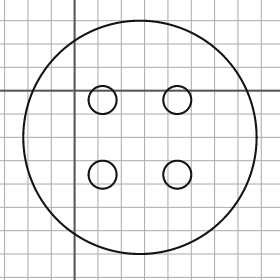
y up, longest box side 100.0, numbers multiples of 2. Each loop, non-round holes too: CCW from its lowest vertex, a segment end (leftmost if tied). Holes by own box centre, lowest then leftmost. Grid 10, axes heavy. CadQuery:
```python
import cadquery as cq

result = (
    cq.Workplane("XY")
    .moveTo(28.0, -20.0)
    .circle(50.0)
    .moveTo(12.0, -36.0)
    .circle(6.0)
    .moveTo(44.0, -36.0)
    .circle(6.0)
    .moveTo(12.0, -4.0)
    .circle(6.0)
    .moveTo(44.0, -4.0)
    .circle(6.0)
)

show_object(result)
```